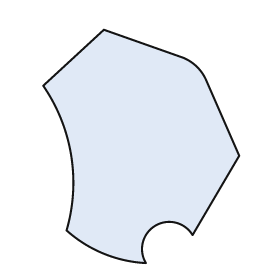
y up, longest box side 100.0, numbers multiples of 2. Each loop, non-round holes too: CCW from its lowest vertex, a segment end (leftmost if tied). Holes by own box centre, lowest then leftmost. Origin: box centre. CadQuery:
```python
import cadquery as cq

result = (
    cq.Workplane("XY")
    .moveTo(2.0, -50.0)
    .threePointArc((6.0, -34.0), (22.0, -38.0))
    .lineTo(42.0, -4.0)
    .lineTo(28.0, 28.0)
    .threePointArc((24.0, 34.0), (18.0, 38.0))
    .lineTo(-16.0, 50.0)
    .lineTo(-42.0, 26.0)
    .threePointArc((-30.0, -4.0), (-32.0, -36.0))
    .threePointArc((-16.0, -46.0), (2.0, -50.0))
    .close()
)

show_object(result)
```